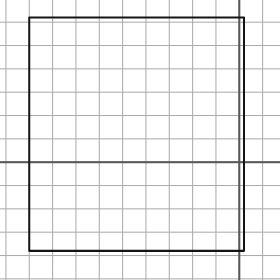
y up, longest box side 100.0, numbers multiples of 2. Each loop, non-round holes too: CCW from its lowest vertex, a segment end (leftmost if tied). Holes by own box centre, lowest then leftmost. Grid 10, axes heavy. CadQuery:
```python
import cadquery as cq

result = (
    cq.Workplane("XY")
    .moveTo(-90.0, -38.0)
    .lineTo(2.0, -38.0)
    .lineTo(2.0, 62.0)
    .lineTo(-90.0, 62.0)
    .close()
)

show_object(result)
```